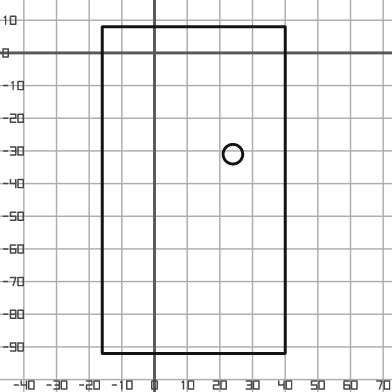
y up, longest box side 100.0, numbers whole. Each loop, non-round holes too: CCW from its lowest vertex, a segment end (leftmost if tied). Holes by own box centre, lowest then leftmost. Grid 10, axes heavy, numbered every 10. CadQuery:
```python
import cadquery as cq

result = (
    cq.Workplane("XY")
    .moveTo(-16.0, -92.0)
    .lineTo(40.0, -92.0)
    .lineTo(40.0, 8.0)
    .lineTo(-16.0, 8.0)
    .close()
    .moveTo(24.0, -31.0)
    .circle(3.0)
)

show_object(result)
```